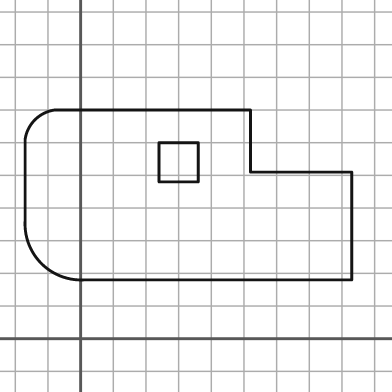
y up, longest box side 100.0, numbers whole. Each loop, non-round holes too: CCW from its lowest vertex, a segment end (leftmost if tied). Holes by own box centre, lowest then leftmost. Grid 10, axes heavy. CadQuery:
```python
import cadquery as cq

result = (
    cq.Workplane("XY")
    .moveTo(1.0, 18.0)
    .lineTo(83.0, 18.0)
    .lineTo(83.0, 51.0)
    .lineTo(52.0, 51.0)
    .lineTo(52.0, 70.0)
    .lineTo(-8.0, 70.0)
    .threePointArc((-14.0, 67.0), (-17.0, 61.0))
    .lineTo(-17.0, 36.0)
    .threePointArc((-12.0, 23.0), (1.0, 18.0))
    .close()
    .moveTo(24.0, 48.0)
    .lineTo(36.0, 48.0)
    .lineTo(36.0, 60.0)
    .lineTo(24.0, 60.0)
    .close()
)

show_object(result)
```